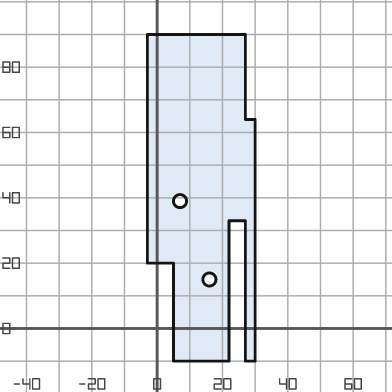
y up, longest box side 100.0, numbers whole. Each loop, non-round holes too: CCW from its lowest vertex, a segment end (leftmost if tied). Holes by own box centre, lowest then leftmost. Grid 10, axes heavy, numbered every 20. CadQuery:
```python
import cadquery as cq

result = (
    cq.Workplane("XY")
    .moveTo(5.0, -10.0)
    .lineTo(22.0, -10.0)
    .lineTo(22.0, 33.0)
    .lineTo(27.0, 33.0)
    .lineTo(27.0, -10.0)
    .lineTo(30.0, -10.0)
    .lineTo(30.0, 64.0)
    .lineTo(27.0, 64.0)
    .lineTo(27.0, 90.0)
    .lineTo(-3.0, 90.0)
    .lineTo(-3.0, 20.0)
    .lineTo(5.0, 20.0)
    .close()
    .moveTo(16.0, 15.0)
    .circle(2.0)
    .moveTo(7.0, 39.0)
    .circle(2.0)
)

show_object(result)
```